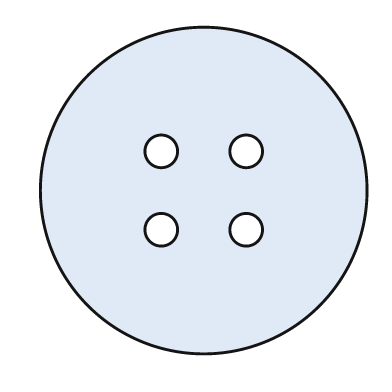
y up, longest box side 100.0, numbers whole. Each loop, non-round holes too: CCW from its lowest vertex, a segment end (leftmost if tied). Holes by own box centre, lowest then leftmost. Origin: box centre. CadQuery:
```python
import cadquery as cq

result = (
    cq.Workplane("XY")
    .moveTo(0.0, 0.0)
    .circle(50.0)
    .moveTo(-13.0, -12.0)
    .circle(5.0)
    .moveTo(13.0, -12.0)
    .circle(5.0)
    .moveTo(-13.0, 12.0)
    .circle(5.0)
    .moveTo(13.0, 12.0)
    .circle(5.0)
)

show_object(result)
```